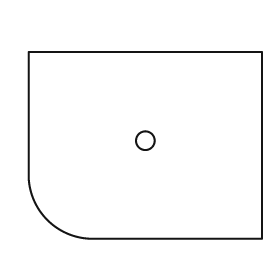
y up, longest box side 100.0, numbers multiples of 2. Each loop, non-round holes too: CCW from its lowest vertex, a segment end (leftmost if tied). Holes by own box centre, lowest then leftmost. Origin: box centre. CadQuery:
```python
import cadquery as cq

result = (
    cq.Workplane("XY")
    .moveTo(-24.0, -40.0)
    .lineTo(50.0, -40.0)
    .lineTo(50.0, 40.0)
    .lineTo(-50.0, 40.0)
    .lineTo(-50.0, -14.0)
    .threePointArc((-42.0, -32.0), (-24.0, -40.0))
    .close()
    .moveTo(0.0, 2.0)
    .circle(4.0)
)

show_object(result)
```